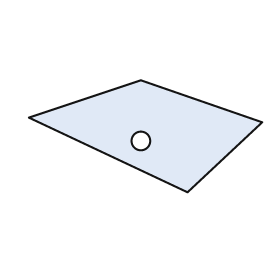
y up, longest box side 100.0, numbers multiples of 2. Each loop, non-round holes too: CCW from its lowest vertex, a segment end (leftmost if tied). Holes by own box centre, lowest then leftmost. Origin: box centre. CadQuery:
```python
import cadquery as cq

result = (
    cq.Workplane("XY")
    .moveTo(18.0, -24.0)
    .lineTo(50.0, 6.0)
    .lineTo(-2.0, 24.0)
    .lineTo(-50.0, 8.0)
    .close()
    .moveTo(-2.0, -2.0)
    .circle(4.0)
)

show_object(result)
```